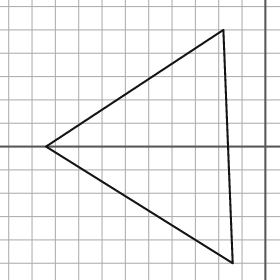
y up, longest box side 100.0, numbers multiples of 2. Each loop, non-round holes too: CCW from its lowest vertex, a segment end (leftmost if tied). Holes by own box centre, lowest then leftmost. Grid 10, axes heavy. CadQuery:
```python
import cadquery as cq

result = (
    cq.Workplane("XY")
    .moveTo(-14.0, -50.0)
    .lineTo(-18.0, 50.0)
    .lineTo(-94.0, 0.0)
    .close()
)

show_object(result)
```